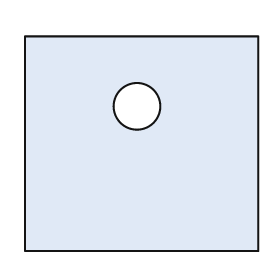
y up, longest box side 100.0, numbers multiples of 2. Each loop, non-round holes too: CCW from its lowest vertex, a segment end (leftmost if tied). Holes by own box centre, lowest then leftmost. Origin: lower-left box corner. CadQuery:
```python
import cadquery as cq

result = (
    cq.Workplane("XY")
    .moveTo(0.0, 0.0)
    .lineTo(100.0, 0.0)
    .lineTo(100.0, 92.0)
    .lineTo(0.0, 92.0)
    .close()
    .moveTo(48.0, 62.0)
    .circle(10.0)
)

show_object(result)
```